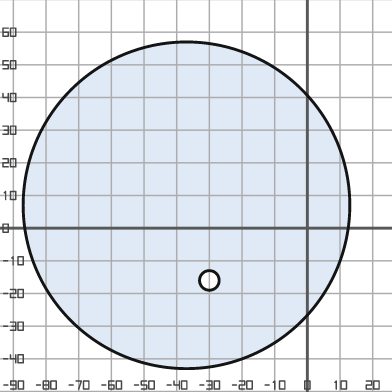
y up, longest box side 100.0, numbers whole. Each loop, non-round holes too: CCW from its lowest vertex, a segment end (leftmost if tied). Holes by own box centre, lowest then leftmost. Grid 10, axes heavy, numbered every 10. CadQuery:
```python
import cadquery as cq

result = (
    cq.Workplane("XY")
    .moveTo(-37.0, 7.0)
    .circle(50.0)
    .moveTo(-30.0, -16.0)
    .circle(3.0)
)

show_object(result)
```